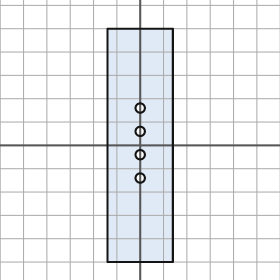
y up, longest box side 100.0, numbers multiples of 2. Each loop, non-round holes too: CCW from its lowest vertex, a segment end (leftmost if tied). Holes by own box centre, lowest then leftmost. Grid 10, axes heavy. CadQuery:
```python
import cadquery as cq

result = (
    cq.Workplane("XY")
    .moveTo(-14.0, -50.0)
    .lineTo(14.0, -50.0)
    .lineTo(14.0, 50.0)
    .lineTo(-14.0, 50.0)
    .close()
    .moveTo(0.0, -14.0)
    .circle(2.0)
    .moveTo(0.0, -4.0)
    .circle(2.0)
    .moveTo(0.0, 6.0)
    .circle(2.0)
    .moveTo(0.0, 16.0)
    .circle(2.0)
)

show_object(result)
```